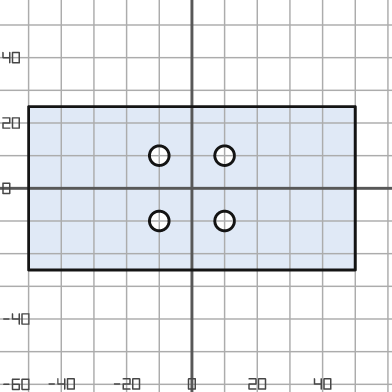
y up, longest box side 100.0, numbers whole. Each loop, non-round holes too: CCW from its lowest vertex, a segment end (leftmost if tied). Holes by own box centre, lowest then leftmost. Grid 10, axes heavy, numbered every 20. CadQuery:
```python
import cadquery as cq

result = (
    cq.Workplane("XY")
    .moveTo(-50.0, -25.0)
    .lineTo(50.0, -25.0)
    .lineTo(50.0, 25.0)
    .lineTo(-50.0, 25.0)
    .close()
    .moveTo(-10.0, -10.0)
    .circle(3.0)
    .moveTo(10.0, -10.0)
    .circle(3.0)
    .moveTo(-10.0, 10.0)
    .circle(3.0)
    .moveTo(10.0, 10.0)
    .circle(3.0)
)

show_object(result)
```